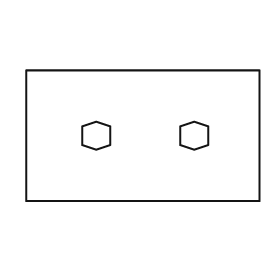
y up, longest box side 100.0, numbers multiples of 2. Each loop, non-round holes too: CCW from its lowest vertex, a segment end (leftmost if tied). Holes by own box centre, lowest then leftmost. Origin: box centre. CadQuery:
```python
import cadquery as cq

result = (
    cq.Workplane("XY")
    .moveTo(-50.0, -28.0)
    .lineTo(50.0, -28.0)
    .lineTo(50.0, 28.0)
    .lineTo(-50.0, 28.0)
    .close()
    .moveTo(-20.0, -6.0)
    .lineTo(-14.0, -4.0)
    .lineTo(-14.0, 4.0)
    .lineTo(-20.0, 6.0)
    .lineTo(-26.0, 4.0)
    .lineTo(-26.0, -4.0)
    .close()
    .moveTo(22.0, -6.0)
    .lineTo(28.0, -4.0)
    .lineTo(28.0, 4.0)
    .lineTo(22.0, 6.0)
    .lineTo(16.0, 4.0)
    .lineTo(16.0, -4.0)
    .close()
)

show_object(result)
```